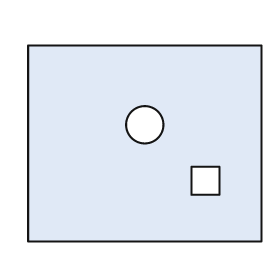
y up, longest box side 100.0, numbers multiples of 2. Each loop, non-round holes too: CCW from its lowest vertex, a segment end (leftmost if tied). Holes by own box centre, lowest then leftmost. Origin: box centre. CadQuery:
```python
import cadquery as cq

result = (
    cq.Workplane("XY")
    .moveTo(-50.0, -42.0)
    .lineTo(50.0, -42.0)
    .lineTo(50.0, 42.0)
    .lineTo(-50.0, 42.0)
    .close()
    .moveTo(20.0, -22.0)
    .lineTo(32.0, -22.0)
    .lineTo(32.0, -10.0)
    .lineTo(20.0, -10.0)
    .close()
    .moveTo(0.0, 8.0)
    .circle(8.0)
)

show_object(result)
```